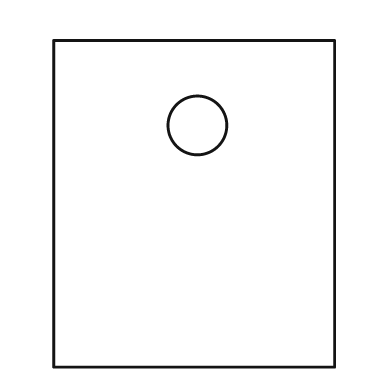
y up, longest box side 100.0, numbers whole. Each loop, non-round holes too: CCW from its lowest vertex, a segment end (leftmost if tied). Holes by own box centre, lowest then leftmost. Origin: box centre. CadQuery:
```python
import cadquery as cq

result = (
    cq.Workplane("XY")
    .moveTo(-43.0, -50.0)
    .lineTo(43.0, -50.0)
    .lineTo(43.0, 50.0)
    .lineTo(-43.0, 50.0)
    .close()
    .moveTo(1.0, 24.0)
    .circle(9.0)
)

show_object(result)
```